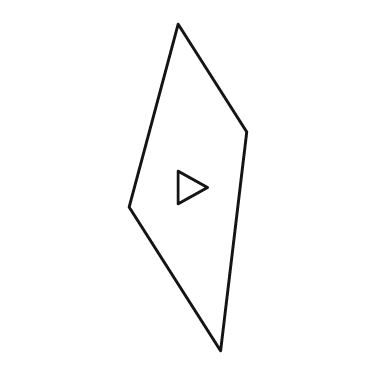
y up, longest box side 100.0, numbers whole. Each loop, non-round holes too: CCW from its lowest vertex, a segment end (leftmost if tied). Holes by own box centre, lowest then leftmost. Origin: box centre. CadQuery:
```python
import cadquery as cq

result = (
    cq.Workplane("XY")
    .moveTo(10.0, -50.0)
    .lineTo(18.0, 17.0)
    .lineTo(-3.0, 50.0)
    .lineTo(-18.0, -6.0)
    .close()
    .moveTo(-3.0, -5.0)
    .lineTo(6.0, 0.0)
    .lineTo(-3.0, 5.0)
    .close()
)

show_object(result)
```